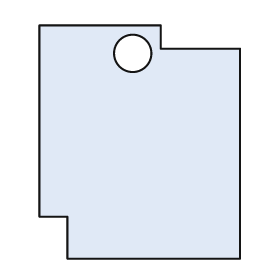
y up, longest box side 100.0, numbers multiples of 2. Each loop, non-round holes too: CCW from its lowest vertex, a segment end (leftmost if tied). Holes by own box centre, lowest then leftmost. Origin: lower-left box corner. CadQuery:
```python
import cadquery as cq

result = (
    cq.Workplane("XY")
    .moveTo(12.0, 0.0)
    .lineTo(86.0, 0.0)
    .lineTo(86.0, 90.0)
    .lineTo(52.0, 90.0)
    .lineTo(52.0, 100.0)
    .lineTo(0.0, 100.0)
    .lineTo(0.0, 18.0)
    .lineTo(12.0, 18.0)
    .close()
    .moveTo(40.0, 88.0)
    .circle(8.0)
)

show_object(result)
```